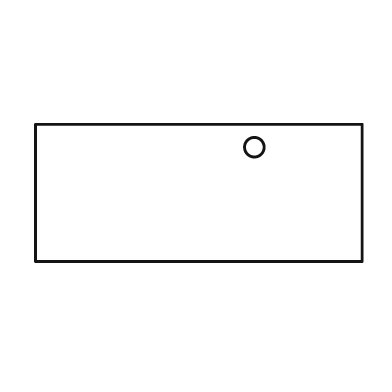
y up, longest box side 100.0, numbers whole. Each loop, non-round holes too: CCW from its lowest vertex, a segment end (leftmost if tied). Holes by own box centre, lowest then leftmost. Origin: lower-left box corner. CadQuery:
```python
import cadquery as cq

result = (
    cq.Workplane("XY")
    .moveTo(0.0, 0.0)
    .lineTo(100.0, 0.0)
    .lineTo(100.0, 42.0)
    .lineTo(0.0, 42.0)
    .close()
    .moveTo(67.0, 35.0)
    .circle(3.0)
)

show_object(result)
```